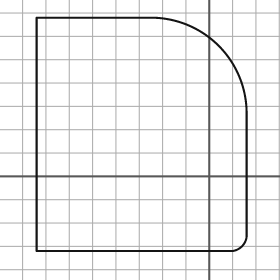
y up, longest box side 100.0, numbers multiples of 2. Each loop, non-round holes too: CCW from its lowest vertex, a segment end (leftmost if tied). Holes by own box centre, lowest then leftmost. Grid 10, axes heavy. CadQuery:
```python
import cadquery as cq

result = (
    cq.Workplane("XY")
    .moveTo(-74.0, -32.0)
    .lineTo(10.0, -32.0)
    .threePointArc((14.0, -30.0), (16.0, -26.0))
    .lineTo(16.0, 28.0)
    .threePointArc((4.0, 56.0), (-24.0, 68.0))
    .lineTo(-74.0, 68.0)
    .close()
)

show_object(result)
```